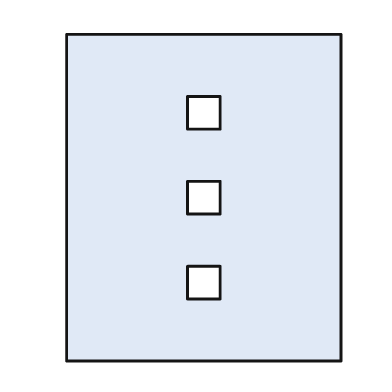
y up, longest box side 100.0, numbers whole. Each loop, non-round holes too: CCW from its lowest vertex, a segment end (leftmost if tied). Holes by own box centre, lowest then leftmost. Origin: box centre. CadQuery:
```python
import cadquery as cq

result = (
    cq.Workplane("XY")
    .moveTo(-42.0, -50.0)
    .lineTo(42.0, -50.0)
    .lineTo(42.0, 50.0)
    .lineTo(-42.0, 50.0)
    .close()
    .moveTo(-5.0, -31.0)
    .lineTo(5.0, -31.0)
    .lineTo(5.0, -21.0)
    .lineTo(-5.0, -21.0)
    .close()
    .moveTo(-5.0, -5.0)
    .lineTo(5.0, -5.0)
    .lineTo(5.0, 5.0)
    .lineTo(-5.0, 5.0)
    .close()
    .moveTo(-5.0, 21.0)
    .lineTo(5.0, 21.0)
    .lineTo(5.0, 31.0)
    .lineTo(-5.0, 31.0)
    .close()
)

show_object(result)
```